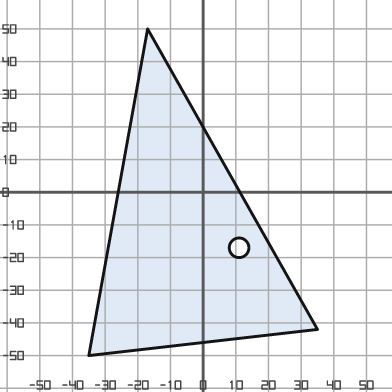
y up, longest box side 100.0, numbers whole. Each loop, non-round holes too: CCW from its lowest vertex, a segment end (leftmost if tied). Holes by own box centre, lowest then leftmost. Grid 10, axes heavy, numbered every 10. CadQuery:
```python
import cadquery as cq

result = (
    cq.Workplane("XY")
    .moveTo(-35.0, -50.0)
    .lineTo(35.0, -42.0)
    .lineTo(-17.0, 50.0)
    .close()
    .moveTo(11.0, -17.0)
    .circle(3.0)
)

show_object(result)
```